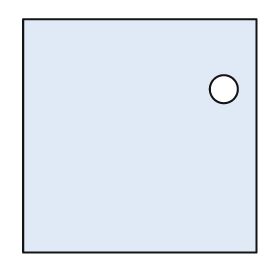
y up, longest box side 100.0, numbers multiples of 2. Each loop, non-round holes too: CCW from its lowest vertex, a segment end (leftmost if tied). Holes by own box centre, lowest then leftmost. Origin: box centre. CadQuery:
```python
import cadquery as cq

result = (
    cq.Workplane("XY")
    .moveTo(-50.0, -50.0)
    .lineTo(50.0, -50.0)
    .lineTo(50.0, 50.0)
    .lineTo(-50.0, 50.0)
    .close()
    .moveTo(36.0, 20.0)
    .circle(6.0)
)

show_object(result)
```